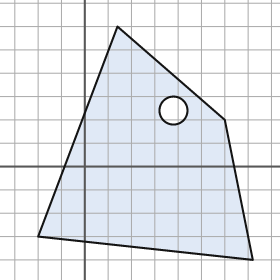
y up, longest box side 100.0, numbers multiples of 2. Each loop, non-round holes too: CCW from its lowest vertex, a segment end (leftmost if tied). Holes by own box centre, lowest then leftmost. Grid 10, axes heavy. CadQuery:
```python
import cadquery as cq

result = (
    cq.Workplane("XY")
    .moveTo(72.0, -40.0)
    .lineTo(60.0, 20.0)
    .lineTo(14.0, 60.0)
    .lineTo(-20.0, -30.0)
    .close()
    .moveTo(38.0, 24.0)
    .circle(6.0)
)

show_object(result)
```